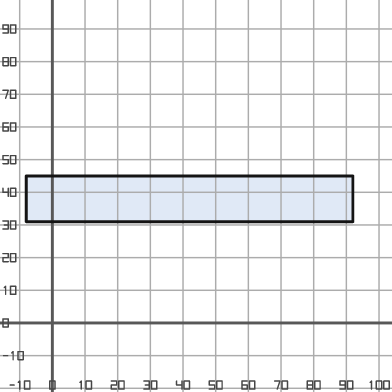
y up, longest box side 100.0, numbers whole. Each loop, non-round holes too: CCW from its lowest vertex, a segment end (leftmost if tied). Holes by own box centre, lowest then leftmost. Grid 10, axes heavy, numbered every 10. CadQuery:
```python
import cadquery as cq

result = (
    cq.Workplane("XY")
    .moveTo(-8.0, 31.0)
    .lineTo(92.0, 31.0)
    .lineTo(92.0, 45.0)
    .lineTo(-8.0, 45.0)
    .close()
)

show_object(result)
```